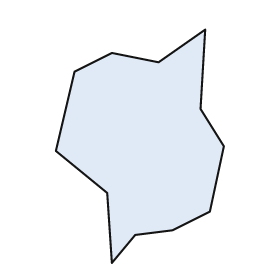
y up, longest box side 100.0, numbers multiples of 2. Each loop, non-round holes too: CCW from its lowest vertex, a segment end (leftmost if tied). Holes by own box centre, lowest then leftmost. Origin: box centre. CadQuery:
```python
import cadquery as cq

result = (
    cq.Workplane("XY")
    .moveTo(-12.0, -50.0)
    .lineTo(-2.0, -38.0)
    .lineTo(14.0, -36.0)
    .lineTo(30.0, -28.0)
    .lineTo(36.0, 0.0)
    .lineTo(26.0, 16.0)
    .lineTo(28.0, 50.0)
    .lineTo(8.0, 36.0)
    .lineTo(-12.0, 40.0)
    .lineTo(-28.0, 32.0)
    .lineTo(-36.0, -2.0)
    .lineTo(-14.0, -20.0)
    .close()
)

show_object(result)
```